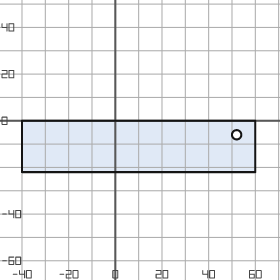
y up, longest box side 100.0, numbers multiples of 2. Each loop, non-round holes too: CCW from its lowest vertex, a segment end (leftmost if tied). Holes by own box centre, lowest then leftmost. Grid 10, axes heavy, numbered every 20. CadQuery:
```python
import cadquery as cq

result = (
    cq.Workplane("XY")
    .moveTo(-40.0, -22.0)
    .lineTo(60.0, -22.0)
    .lineTo(60.0, 0.0)
    .lineTo(-40.0, 0.0)
    .close()
    .moveTo(52.0, -6.0)
    .circle(2.0)
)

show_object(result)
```